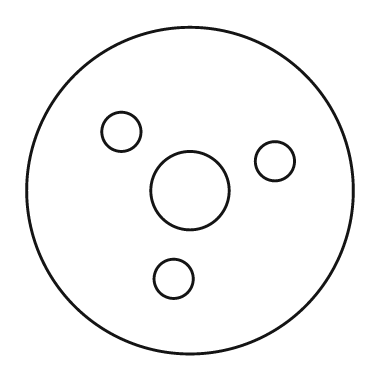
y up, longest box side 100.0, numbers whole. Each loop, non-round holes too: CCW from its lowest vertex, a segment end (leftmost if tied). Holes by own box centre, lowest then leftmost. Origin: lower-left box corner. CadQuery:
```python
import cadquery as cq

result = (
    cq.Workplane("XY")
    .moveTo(50.0, 50.0)
    .circle(50.0)
    .moveTo(45.0, 23.0)
    .circle(6.0)
    .moveTo(50.0, 50.0)
    .circle(12.0)
    .moveTo(76.0, 59.0)
    .circle(6.0)
    .moveTo(29.0, 68.0)
    .circle(6.0)
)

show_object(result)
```